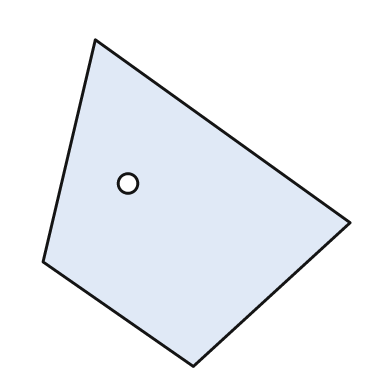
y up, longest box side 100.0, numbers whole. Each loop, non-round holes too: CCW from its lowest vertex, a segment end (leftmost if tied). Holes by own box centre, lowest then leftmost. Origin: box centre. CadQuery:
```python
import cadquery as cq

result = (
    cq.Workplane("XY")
    .moveTo(-1.0, -50.0)
    .lineTo(47.0, -6.0)
    .lineTo(-31.0, 50.0)
    .lineTo(-47.0, -18.0)
    .close()
    .moveTo(-21.0, 6.0)
    .circle(3.0)
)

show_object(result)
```